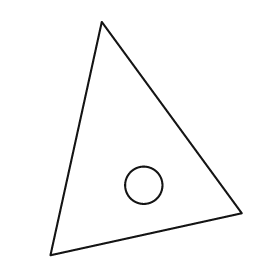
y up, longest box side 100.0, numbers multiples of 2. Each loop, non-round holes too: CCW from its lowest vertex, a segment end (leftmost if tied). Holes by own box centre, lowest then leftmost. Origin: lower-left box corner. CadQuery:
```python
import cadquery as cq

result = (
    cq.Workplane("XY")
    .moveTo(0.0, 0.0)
    .lineTo(82.0, 18.0)
    .lineTo(22.0, 100.0)
    .close()
    .moveTo(40.0, 30.0)
    .circle(8.0)
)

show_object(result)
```